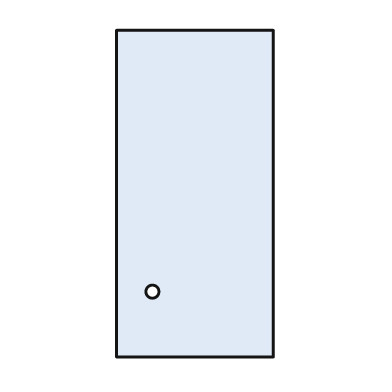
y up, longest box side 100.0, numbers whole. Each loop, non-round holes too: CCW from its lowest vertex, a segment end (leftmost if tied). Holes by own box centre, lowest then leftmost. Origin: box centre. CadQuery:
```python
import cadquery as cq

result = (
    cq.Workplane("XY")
    .moveTo(-24.0, -50.0)
    .lineTo(24.0, -50.0)
    .lineTo(24.0, 50.0)
    .lineTo(-24.0, 50.0)
    .close()
    .moveTo(-13.0, -30.0)
    .circle(2.0)
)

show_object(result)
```